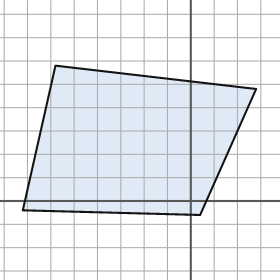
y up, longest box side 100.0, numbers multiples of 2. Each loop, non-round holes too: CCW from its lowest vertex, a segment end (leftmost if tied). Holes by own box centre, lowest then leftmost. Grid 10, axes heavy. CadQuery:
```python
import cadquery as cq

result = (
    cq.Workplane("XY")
    .moveTo(4.0, -6.0)
    .lineTo(28.0, 48.0)
    .lineTo(-58.0, 58.0)
    .lineTo(-72.0, -4.0)
    .close()
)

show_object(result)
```